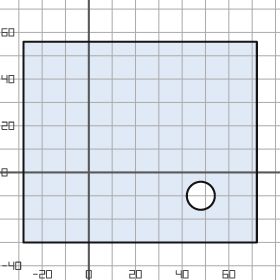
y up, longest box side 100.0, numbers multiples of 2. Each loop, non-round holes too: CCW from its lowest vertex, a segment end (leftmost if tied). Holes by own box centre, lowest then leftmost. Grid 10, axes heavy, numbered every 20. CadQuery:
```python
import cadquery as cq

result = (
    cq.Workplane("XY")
    .moveTo(-28.0, -30.0)
    .lineTo(72.0, -30.0)
    .lineTo(72.0, 56.0)
    .lineTo(-28.0, 56.0)
    .close()
    .moveTo(48.0, -10.0)
    .circle(6.0)
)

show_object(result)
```